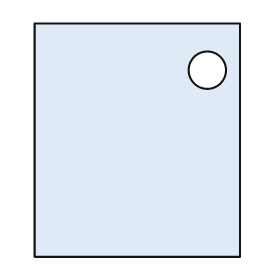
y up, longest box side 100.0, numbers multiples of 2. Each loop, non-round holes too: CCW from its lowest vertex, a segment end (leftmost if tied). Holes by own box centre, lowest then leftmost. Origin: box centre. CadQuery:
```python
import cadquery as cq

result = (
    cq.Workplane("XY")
    .moveTo(-44.0, -50.0)
    .lineTo(44.0, -50.0)
    .lineTo(44.0, 50.0)
    .lineTo(-44.0, 50.0)
    .close()
    .moveTo(30.0, 30.0)
    .circle(8.0)
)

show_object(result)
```